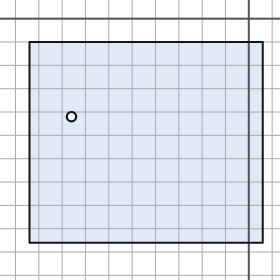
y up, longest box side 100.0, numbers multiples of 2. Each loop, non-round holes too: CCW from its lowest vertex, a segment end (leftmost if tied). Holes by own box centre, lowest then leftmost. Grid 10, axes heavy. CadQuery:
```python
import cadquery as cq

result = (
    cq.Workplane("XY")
    .moveTo(-94.0, -96.0)
    .lineTo(6.0, -96.0)
    .lineTo(6.0, -10.0)
    .lineTo(-94.0, -10.0)
    .close()
    .moveTo(-76.0, -42.0)
    .circle(2.0)
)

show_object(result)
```